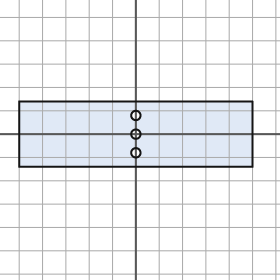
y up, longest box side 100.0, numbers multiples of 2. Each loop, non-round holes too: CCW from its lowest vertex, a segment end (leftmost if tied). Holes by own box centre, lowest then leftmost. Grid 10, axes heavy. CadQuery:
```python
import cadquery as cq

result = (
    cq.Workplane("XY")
    .moveTo(-50.0, -14.0)
    .lineTo(50.0, -14.0)
    .lineTo(50.0, 14.0)
    .lineTo(-50.0, 14.0)
    .close()
    .moveTo(0.0, -8.0)
    .circle(2.0)
    .moveTo(0.0, 0.0)
    .circle(2.0)
    .moveTo(0.0, 8.0)
    .circle(2.0)
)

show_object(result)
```